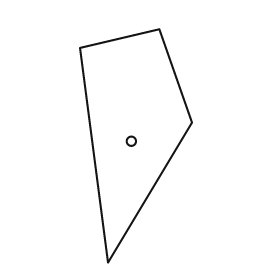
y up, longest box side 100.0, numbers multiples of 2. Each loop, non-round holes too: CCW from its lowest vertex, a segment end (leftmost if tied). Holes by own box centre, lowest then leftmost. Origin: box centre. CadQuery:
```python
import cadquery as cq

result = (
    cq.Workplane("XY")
    .moveTo(-12.0, -50.0)
    .lineTo(24.0, 10.0)
    .lineTo(10.0, 50.0)
    .lineTo(-24.0, 42.0)
    .close()
    .moveTo(-2.0, 2.0)
    .circle(2.0)
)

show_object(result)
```